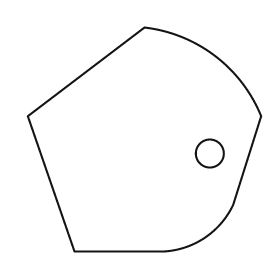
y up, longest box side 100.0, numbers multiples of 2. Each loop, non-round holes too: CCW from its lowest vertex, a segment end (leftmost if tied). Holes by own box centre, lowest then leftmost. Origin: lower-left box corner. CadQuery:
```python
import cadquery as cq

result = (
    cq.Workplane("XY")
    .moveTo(20.0, 0.0)
    .lineTo(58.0, 0.0)
    .threePointArc((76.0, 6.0), (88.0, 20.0))
    .lineTo(100.0, 58.0)
    .threePointArc((80.0, 84.0), (50.0, 96.0))
    .lineTo(0.0, 58.0)
    .close()
    .moveTo(78.0, 42.0)
    .circle(6.0)
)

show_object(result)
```